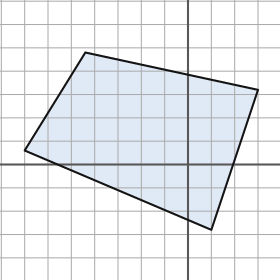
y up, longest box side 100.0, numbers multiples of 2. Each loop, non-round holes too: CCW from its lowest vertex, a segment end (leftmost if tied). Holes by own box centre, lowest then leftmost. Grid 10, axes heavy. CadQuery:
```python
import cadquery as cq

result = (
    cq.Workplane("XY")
    .moveTo(10.0, -28.0)
    .lineTo(30.0, 32.0)
    .lineTo(-44.0, 48.0)
    .lineTo(-70.0, 6.0)
    .close()
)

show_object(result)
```